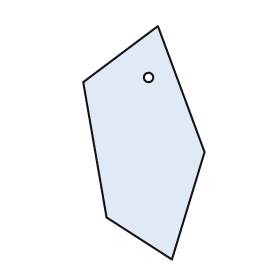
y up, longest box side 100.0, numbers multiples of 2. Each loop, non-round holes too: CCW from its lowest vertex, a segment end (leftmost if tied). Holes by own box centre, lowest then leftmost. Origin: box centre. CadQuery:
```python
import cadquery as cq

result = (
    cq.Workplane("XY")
    .moveTo(12.0, -50.0)
    .lineTo(26.0, -4.0)
    .lineTo(6.0, 50.0)
    .lineTo(-26.0, 26.0)
    .lineTo(-16.0, -32.0)
    .close()
    .moveTo(2.0, 28.0)
    .circle(2.0)
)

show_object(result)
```